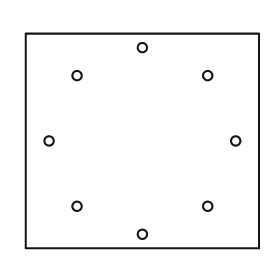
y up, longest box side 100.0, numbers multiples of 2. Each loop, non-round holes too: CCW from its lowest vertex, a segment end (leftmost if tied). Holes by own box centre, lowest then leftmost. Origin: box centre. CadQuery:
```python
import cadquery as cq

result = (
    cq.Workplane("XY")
    .moveTo(-50.0, -46.0)
    .lineTo(50.0, -46.0)
    .lineTo(50.0, 46.0)
    .lineTo(-50.0, 46.0)
    .close()
    .moveTo(0.0, -40.0)
    .circle(2.0)
    .moveTo(-28.0, -28.0)
    .circle(2.0)
    .moveTo(28.0, -28.0)
    .circle(2.0)
    .moveTo(-40.0, 0.0)
    .circle(2.0)
    .moveTo(40.0, 0.0)
    .circle(2.0)
    .moveTo(-28.0, 28.0)
    .circle(2.0)
    .moveTo(28.0, 28.0)
    .circle(2.0)
    .moveTo(0.0, 40.0)
    .circle(2.0)
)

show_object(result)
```